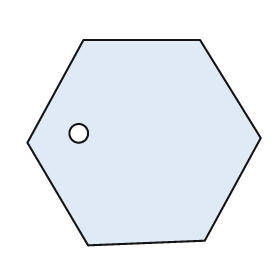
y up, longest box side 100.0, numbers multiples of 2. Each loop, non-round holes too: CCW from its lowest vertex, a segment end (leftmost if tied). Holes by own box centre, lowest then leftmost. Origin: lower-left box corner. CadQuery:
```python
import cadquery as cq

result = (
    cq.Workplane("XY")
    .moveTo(26.0, 0.0)
    .lineTo(76.0, 2.0)
    .lineTo(100.0, 46.0)
    .lineTo(74.0, 88.0)
    .lineTo(24.0, 88.0)
    .lineTo(0.0, 44.0)
    .close()
    .moveTo(22.0, 48.0)
    .circle(4.0)
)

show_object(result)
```